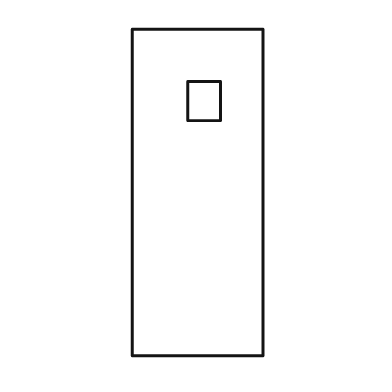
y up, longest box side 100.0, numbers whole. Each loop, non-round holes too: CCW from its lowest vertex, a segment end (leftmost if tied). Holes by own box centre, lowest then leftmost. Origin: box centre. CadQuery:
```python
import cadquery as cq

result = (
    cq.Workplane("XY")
    .moveTo(-20.0, -50.0)
    .lineTo(20.0, -50.0)
    .lineTo(20.0, 50.0)
    .lineTo(-20.0, 50.0)
    .close()
    .moveTo(-3.0, 22.0)
    .lineTo(7.0, 22.0)
    .lineTo(7.0, 34.0)
    .lineTo(-3.0, 34.0)
    .close()
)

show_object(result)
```